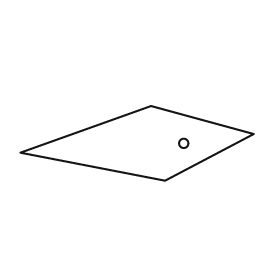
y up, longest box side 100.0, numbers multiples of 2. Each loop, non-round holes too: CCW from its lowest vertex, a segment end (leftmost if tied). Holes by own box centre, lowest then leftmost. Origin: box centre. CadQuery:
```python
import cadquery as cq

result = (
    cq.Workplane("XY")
    .moveTo(12.0, -16.0)
    .lineTo(50.0, 4.0)
    .lineTo(6.0, 16.0)
    .lineTo(-50.0, -4.0)
    .close()
    .moveTo(20.0, 0.0)
    .circle(2.0)
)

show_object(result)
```